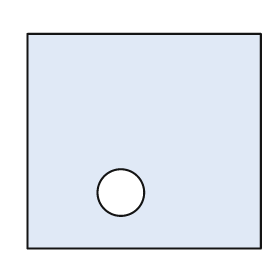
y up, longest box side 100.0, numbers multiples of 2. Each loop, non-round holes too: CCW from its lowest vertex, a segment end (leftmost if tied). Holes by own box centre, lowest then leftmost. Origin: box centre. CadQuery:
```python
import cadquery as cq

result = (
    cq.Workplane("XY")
    .moveTo(-50.0, -46.0)
    .lineTo(50.0, -46.0)
    .lineTo(50.0, 46.0)
    .lineTo(-50.0, 46.0)
    .close()
    .moveTo(-10.0, -22.0)
    .circle(10.0)
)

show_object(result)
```